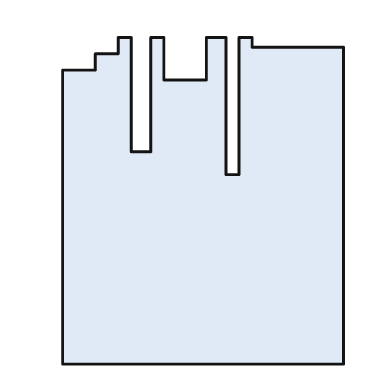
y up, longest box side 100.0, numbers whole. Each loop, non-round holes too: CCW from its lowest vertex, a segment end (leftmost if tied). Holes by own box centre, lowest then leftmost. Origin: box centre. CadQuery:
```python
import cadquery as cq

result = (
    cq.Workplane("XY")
    .moveTo(-43.0, -50.0)
    .lineTo(43.0, -50.0)
    .lineTo(43.0, 47.0)
    .lineTo(15.0, 47.0)
    .lineTo(15.0, 50.0)
    .lineTo(11.0, 50.0)
    .lineTo(11.0, 8.0)
    .lineTo(7.0, 8.0)
    .lineTo(7.0, 50.0)
    .lineTo(1.0, 50.0)
    .lineTo(1.0, 37.0)
    .lineTo(-12.0, 37.0)
    .lineTo(-12.0, 50.0)
    .lineTo(-16.0, 50.0)
    .lineTo(-16.0, 15.0)
    .lineTo(-22.0, 15.0)
    .lineTo(-22.0, 50.0)
    .lineTo(-26.0, 50.0)
    .lineTo(-26.0, 45.0)
    .lineTo(-33.0, 45.0)
    .lineTo(-33.0, 40.0)
    .lineTo(-43.0, 40.0)
    .close()
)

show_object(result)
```